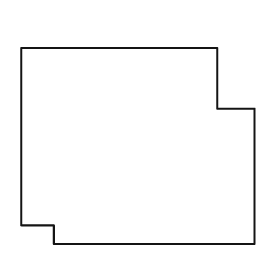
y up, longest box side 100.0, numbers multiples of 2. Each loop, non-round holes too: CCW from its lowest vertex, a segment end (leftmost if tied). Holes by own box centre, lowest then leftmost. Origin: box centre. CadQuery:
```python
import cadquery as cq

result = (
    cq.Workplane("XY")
    .moveTo(-36.0, -42.0)
    .lineTo(50.0, -42.0)
    .lineTo(50.0, 16.0)
    .lineTo(34.0, 16.0)
    .lineTo(34.0, 42.0)
    .lineTo(-50.0, 42.0)
    .lineTo(-50.0, -34.0)
    .lineTo(-36.0, -34.0)
    .close()
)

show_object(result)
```